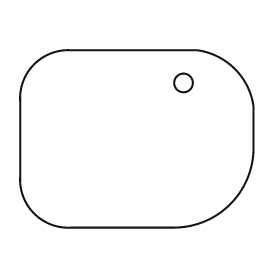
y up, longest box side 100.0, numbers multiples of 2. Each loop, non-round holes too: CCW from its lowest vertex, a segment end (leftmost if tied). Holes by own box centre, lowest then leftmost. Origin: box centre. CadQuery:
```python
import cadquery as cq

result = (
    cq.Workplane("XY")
    .moveTo(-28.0, -38.0)
    .lineTo(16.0, -38.0)
    .threePointArc((40.0, -28.0), (50.0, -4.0))
    .lineTo(50.0, 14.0)
    .threePointArc((42.0, 30.0), (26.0, 38.0))
    .lineTo(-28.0, 38.0)
    .threePointArc((-44.0, 32.0), (-50.0, 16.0))
    .lineTo(-50.0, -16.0)
    .threePointArc((-44.0, -32.0), (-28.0, -38.0))
    .close()
    .moveTo(20.0, 24.0)
    .circle(4.0)
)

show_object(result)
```